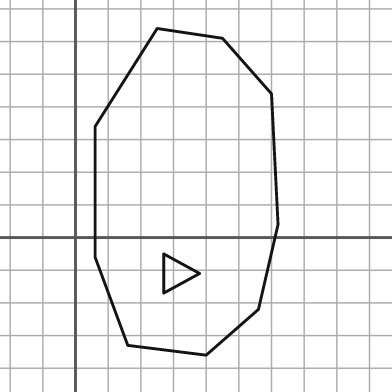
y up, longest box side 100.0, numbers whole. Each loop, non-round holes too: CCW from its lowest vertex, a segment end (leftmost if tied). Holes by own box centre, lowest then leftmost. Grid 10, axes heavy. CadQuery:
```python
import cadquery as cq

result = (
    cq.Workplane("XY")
    .moveTo(40.0, -36.0)
    .lineTo(56.0, -22.0)
    .lineTo(62.0, 4.0)
    .lineTo(60.0, 44.0)
    .lineTo(45.0, 61.0)
    .lineTo(25.0, 64.0)
    .lineTo(6.0, 34.0)
    .lineTo(6.0, -6.0)
    .lineTo(16.0, -33.0)
    .close()
    .moveTo(27.0, -17.0)
    .lineTo(38.0, -11.0)
    .lineTo(27.0, -5.0)
    .close()
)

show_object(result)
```